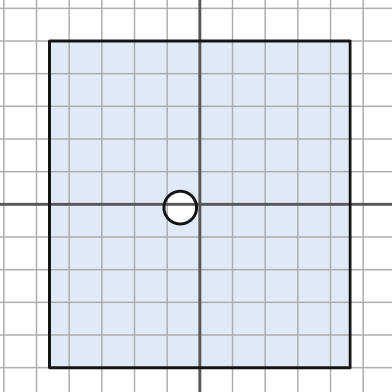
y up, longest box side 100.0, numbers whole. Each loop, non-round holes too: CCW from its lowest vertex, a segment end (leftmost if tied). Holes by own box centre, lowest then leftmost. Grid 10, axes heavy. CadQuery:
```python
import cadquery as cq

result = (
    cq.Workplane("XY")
    .moveTo(-46.0, -50.0)
    .lineTo(46.0, -50.0)
    .lineTo(46.0, 50.0)
    .lineTo(-46.0, 50.0)
    .close()
    .moveTo(-6.0, -1.0)
    .circle(5.0)
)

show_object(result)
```